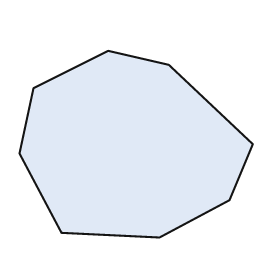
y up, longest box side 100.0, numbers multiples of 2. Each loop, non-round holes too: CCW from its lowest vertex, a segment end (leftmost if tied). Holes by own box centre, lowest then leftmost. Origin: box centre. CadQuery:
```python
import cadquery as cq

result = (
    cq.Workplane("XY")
    .moveTo(10.0, -40.0)
    .lineTo(40.0, -24.0)
    .lineTo(50.0, 0.0)
    .lineTo(14.0, 34.0)
    .lineTo(-12.0, 40.0)
    .lineTo(-44.0, 24.0)
    .lineTo(-50.0, -4.0)
    .lineTo(-32.0, -38.0)
    .close()
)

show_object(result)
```